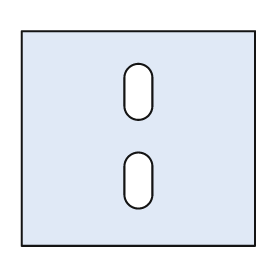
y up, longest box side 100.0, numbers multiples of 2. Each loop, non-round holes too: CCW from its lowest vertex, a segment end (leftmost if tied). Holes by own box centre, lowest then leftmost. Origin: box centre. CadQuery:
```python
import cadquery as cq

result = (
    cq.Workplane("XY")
    .moveTo(-50.0, -46.0)
    .lineTo(50.0, -46.0)
    .lineTo(50.0, 46.0)
    .lineTo(-50.0, 46.0)
    .close()
    .moveTo(-6.0, -24.0)
    .threePointArc((0.0, -30.0), (6.0, -24.0))
    .lineTo(6.0, -12.0)
    .threePointArc((0.0, -6.0), (-6.0, -12.0))
    .close()
    .moveTo(-6.0, 14.0)
    .threePointArc((0.0, 8.0), (6.0, 14.0))
    .lineTo(6.0, 26.0)
    .threePointArc((0.0, 32.0), (-6.0, 26.0))
    .close()
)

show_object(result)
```